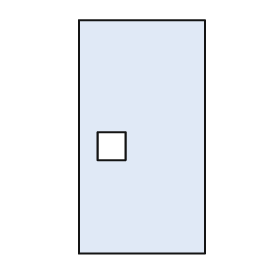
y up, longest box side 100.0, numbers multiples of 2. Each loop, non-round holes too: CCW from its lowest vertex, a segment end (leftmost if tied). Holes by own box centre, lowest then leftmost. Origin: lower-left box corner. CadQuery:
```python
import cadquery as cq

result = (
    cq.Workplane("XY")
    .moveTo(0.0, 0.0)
    .lineTo(54.0, 0.0)
    .lineTo(54.0, 100.0)
    .lineTo(0.0, 100.0)
    .close()
    .moveTo(8.0, 40.0)
    .lineTo(20.0, 40.0)
    .lineTo(20.0, 52.0)
    .lineTo(8.0, 52.0)
    .close()
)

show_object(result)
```